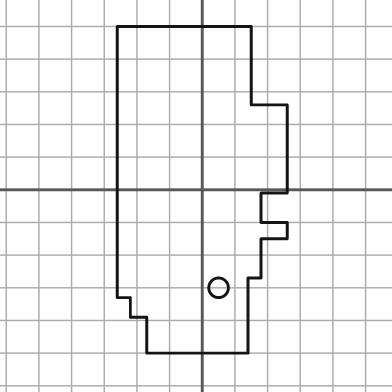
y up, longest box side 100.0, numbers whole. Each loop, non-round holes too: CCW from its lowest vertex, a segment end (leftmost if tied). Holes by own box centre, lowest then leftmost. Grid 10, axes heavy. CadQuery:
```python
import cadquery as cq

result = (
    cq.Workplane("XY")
    .moveTo(-17.0, -50.0)
    .lineTo(14.0, -50.0)
    .lineTo(14.0, -27.0)
    .lineTo(18.0, -27.0)
    .lineTo(18.0, -15.0)
    .lineTo(26.0, -15.0)
    .lineTo(26.0, -10.0)
    .lineTo(18.0, -10.0)
    .lineTo(18.0, -1.0)
    .lineTo(26.0, -1.0)
    .lineTo(26.0, 26.0)
    .lineTo(15.0, 26.0)
    .lineTo(15.0, 50.0)
    .lineTo(-26.0, 50.0)
    .lineTo(-26.0, -33.0)
    .lineTo(-22.0, -33.0)
    .lineTo(-22.0, -39.0)
    .lineTo(-17.0, -39.0)
    .close()
    .moveTo(5.0, -30.0)
    .circle(3.0)
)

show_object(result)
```